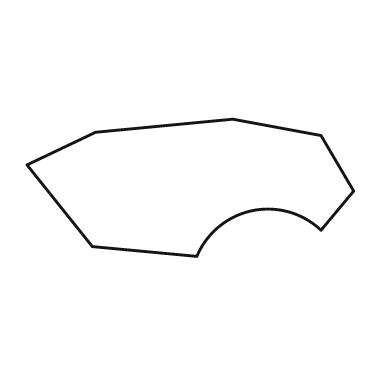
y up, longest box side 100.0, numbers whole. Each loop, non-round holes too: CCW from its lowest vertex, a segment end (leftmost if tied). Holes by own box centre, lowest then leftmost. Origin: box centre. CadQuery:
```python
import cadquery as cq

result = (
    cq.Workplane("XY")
    .moveTo(2.0, -21.0)
    .threePointArc((19.0, -7.0), (40.0, -13.0))
    .lineTo(50.0, -1.0)
    .lineTo(40.0, 16.0)
    .lineTo(13.0, 21.0)
    .lineTo(-29.0, 17.0)
    .lineTo(-50.0, 7.0)
    .lineTo(-30.0, -18.0)
    .close()
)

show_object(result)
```